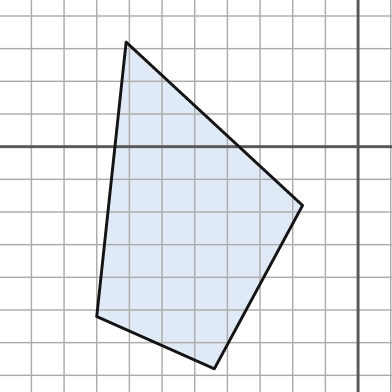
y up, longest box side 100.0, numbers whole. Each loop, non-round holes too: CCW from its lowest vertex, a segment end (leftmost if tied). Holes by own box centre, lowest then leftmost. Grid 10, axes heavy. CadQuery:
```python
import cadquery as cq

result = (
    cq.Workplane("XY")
    .moveTo(-44.0, -68.0)
    .lineTo(-17.0, -18.0)
    .lineTo(-71.0, 32.0)
    .lineTo(-80.0, -52.0)
    .close()
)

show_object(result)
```